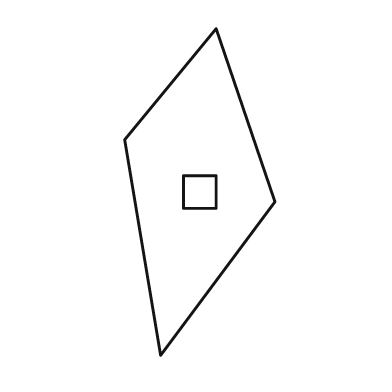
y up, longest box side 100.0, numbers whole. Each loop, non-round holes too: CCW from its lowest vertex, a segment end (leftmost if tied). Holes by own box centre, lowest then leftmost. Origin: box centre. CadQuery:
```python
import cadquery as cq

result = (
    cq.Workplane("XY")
    .moveTo(-12.0, -50.0)
    .lineTo(23.0, -3.0)
    .lineTo(5.0, 50.0)
    .lineTo(-23.0, 16.0)
    .close()
    .moveTo(-5.0, -5.0)
    .lineTo(5.0, -5.0)
    .lineTo(5.0, 5.0)
    .lineTo(-5.0, 5.0)
    .close()
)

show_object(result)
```